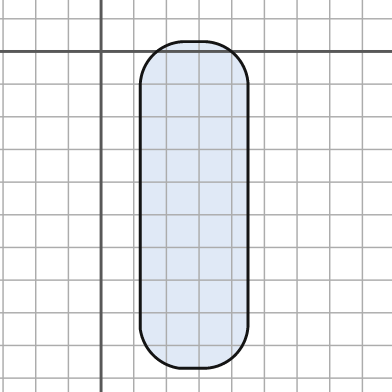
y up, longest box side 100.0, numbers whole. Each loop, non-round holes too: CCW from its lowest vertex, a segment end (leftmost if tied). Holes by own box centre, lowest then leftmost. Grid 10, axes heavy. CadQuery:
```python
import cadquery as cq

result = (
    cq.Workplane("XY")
    .moveTo(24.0, -97.0)
    .lineTo(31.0, -97.0)
    .threePointArc((41.0, -93.0), (45.0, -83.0))
    .lineTo(45.0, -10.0)
    .threePointArc((41.0, -1.0), (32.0, 3.0))
    .lineTo(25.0, 3.0)
    .threePointArc((16.0, -1.0), (12.0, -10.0))
    .lineTo(12.0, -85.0)
    .threePointArc((16.0, -93.0), (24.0, -97.0))
    .close()
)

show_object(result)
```